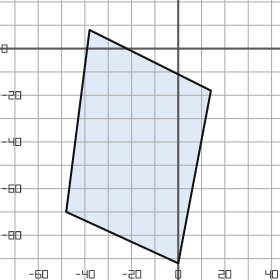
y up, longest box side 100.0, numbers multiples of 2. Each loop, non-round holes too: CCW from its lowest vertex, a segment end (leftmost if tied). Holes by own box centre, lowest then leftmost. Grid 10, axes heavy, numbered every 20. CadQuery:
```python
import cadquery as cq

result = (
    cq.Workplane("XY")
    .moveTo(0.0, -92.0)
    .lineTo(14.0, -18.0)
    .lineTo(-38.0, 8.0)
    .lineTo(-48.0, -70.0)
    .close()
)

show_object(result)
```